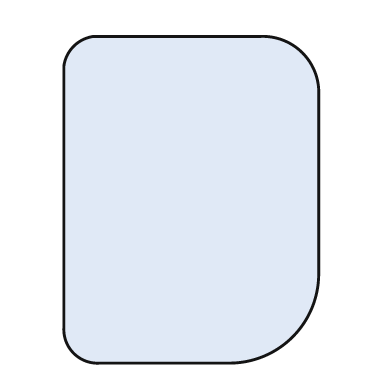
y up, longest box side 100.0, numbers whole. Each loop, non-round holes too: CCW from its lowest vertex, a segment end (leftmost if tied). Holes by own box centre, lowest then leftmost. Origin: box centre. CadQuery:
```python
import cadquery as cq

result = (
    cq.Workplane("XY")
    .moveTo(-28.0, -50.0)
    .lineTo(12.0, -50.0)
    .threePointArc((31.0, -42.0), (39.0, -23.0))
    .lineTo(39.0, 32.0)
    .threePointArc((34.0, 45.0), (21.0, 50.0))
    .lineTo(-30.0, 50.0)
    .threePointArc((-36.0, 47.0), (-39.0, 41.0))
    .lineTo(-39.0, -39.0)
    .threePointArc((-36.0, -47.0), (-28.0, -50.0))
    .close()
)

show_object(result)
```